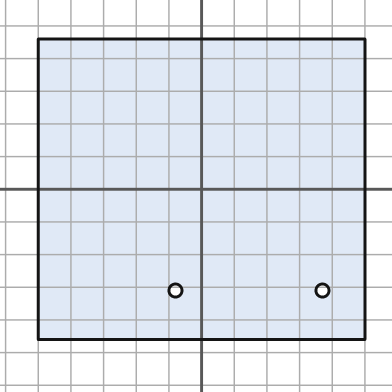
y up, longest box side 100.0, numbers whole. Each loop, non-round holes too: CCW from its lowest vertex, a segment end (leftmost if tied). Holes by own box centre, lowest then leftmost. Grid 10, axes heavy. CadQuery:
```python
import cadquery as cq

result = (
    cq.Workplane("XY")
    .moveTo(-50.0, -46.0)
    .lineTo(50.0, -46.0)
    .lineTo(50.0, 46.0)
    .lineTo(-50.0, 46.0)
    .close()
    .moveTo(-8.0, -31.0)
    .circle(2.0)
    .moveTo(37.0, -31.0)
    .circle(2.0)
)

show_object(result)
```